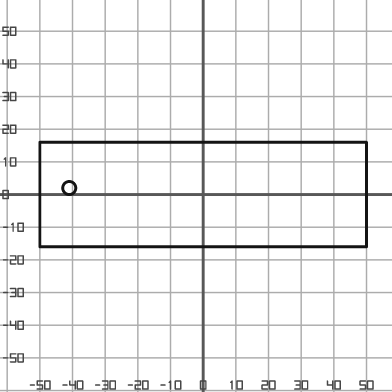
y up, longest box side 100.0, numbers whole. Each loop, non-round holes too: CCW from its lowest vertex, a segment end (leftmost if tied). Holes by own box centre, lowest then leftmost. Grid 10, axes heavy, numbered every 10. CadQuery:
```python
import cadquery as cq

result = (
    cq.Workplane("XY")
    .moveTo(-50.0, -16.0)
    .lineTo(50.0, -16.0)
    .lineTo(50.0, 16.0)
    .lineTo(-50.0, 16.0)
    .close()
    .moveTo(-41.0, 2.0)
    .circle(2.0)
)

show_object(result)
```